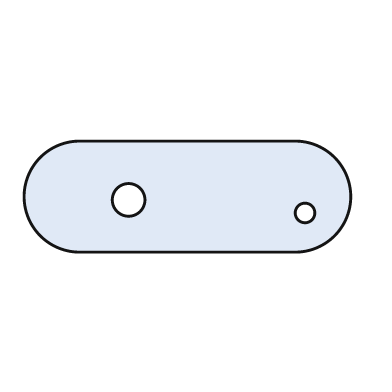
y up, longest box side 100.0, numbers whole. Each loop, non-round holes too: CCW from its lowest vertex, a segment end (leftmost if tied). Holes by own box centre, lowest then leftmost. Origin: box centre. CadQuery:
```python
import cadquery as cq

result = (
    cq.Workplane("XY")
    .moveTo(-33.0, -17.0)
    .lineTo(33.0, -17.0)
    .threePointArc((50.0, 0.0), (33.0, 17.0))
    .lineTo(-33.0, 17.0)
    .threePointArc((-50.0, 0.0), (-33.0, -17.0))
    .close()
    .moveTo(36.0, -5.0)
    .circle(3.0)
    .moveTo(-18.0, -1.0)
    .circle(5.0)
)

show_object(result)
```